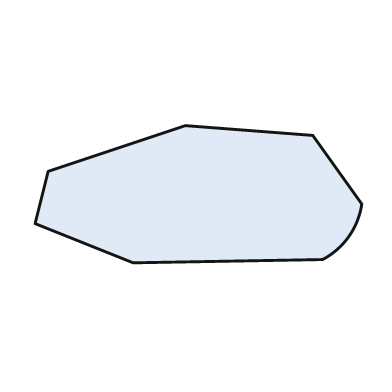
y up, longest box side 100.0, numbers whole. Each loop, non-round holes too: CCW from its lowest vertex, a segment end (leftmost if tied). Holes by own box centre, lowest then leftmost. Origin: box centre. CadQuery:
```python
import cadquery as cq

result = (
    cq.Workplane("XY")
    .moveTo(-20.0, -21.0)
    .lineTo(38.0, -20.0)
    .threePointArc((46.0, -13.0), (50.0, -3.0))
    .lineTo(35.0, 18.0)
    .lineTo(-4.0, 21.0)
    .lineTo(-46.0, 7.0)
    .lineTo(-50.0, -9.0)
    .close()
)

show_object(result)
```